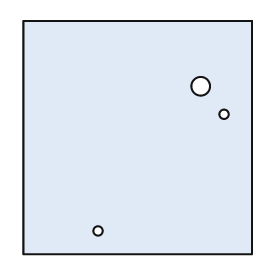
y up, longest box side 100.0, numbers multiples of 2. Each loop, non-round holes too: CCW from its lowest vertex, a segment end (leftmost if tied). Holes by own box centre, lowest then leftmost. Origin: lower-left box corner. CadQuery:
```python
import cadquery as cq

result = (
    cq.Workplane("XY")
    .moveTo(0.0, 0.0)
    .lineTo(98.0, 0.0)
    .lineTo(98.0, 100.0)
    .lineTo(0.0, 100.0)
    .close()
    .moveTo(32.0, 10.0)
    .circle(2.0)
    .moveTo(86.0, 60.0)
    .circle(2.0)
    .moveTo(76.0, 72.0)
    .circle(4.0)
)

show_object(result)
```